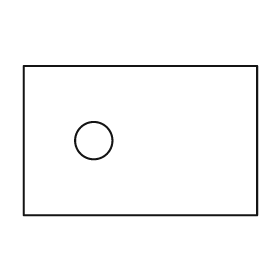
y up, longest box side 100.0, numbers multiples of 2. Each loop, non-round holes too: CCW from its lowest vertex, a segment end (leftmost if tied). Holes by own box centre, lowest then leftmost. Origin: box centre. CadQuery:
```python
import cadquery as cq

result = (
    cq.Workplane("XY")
    .moveTo(-50.0, -32.0)
    .lineTo(50.0, -32.0)
    .lineTo(50.0, 32.0)
    .lineTo(-50.0, 32.0)
    .close()
    .moveTo(-20.0, 0.0)
    .circle(8.0)
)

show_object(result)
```